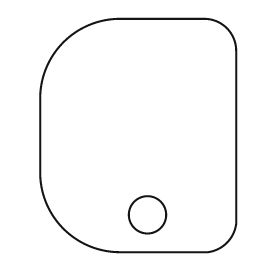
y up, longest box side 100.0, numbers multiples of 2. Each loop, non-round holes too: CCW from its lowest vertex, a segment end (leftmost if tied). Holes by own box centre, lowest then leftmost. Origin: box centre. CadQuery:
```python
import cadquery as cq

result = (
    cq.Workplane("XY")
    .moveTo(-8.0, -50.0)
    .lineTo(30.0, -50.0)
    .threePointArc((38.0, -46.0), (42.0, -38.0))
    .lineTo(42.0, 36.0)
    .threePointArc((38.0, 46.0), (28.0, 50.0))
    .lineTo(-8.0, 50.0)
    .threePointArc((-32.0, 40.0), (-42.0, 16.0))
    .lineTo(-42.0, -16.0)
    .threePointArc((-32.0, -40.0), (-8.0, -50.0))
    .close()
    .moveTo(4.0, -34.0)
    .circle(8.0)
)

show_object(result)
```